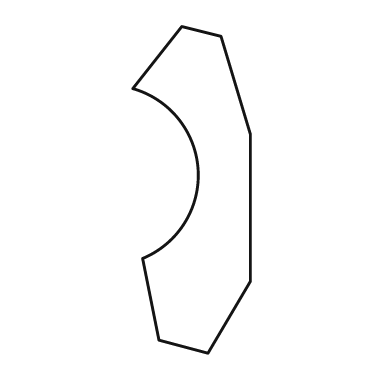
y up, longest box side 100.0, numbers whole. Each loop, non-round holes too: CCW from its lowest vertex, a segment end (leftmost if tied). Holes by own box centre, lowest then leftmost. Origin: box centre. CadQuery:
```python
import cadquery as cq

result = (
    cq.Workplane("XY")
    .moveTo(5.0, -50.0)
    .lineTo(18.0, -28.0)
    .lineTo(18.0, 17.0)
    .lineTo(9.0, 47.0)
    .lineTo(-3.0, 50.0)
    .lineTo(-18.0, 31.0)
    .threePointArc((2.0, 6.0), (-15.0, -21.0))
    .lineTo(-10.0, -46.0)
    .close()
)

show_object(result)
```